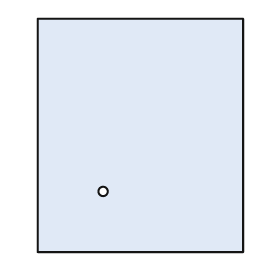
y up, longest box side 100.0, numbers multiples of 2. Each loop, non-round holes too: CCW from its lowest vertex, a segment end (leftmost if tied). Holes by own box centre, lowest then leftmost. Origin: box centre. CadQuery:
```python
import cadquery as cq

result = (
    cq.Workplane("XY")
    .moveTo(-44.0, -50.0)
    .lineTo(44.0, -50.0)
    .lineTo(44.0, 50.0)
    .lineTo(-44.0, 50.0)
    .close()
    .moveTo(-16.0, -24.0)
    .circle(2.0)
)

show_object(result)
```